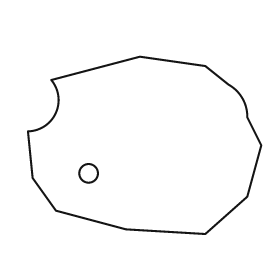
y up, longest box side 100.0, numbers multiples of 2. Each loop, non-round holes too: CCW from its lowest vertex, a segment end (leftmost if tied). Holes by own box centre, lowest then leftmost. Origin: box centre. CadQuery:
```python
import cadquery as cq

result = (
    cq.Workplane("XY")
    .moveTo(26.0, -38.0)
    .lineTo(44.0, -22.0)
    .lineTo(50.0, 0.0)
    .lineTo(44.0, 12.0)
    .threePointArc((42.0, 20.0), (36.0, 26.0))
    .lineTo(26.0, 34.0)
    .lineTo(-2.0, 38.0)
    .lineTo(-40.0, 28.0)
    .threePointArc((-38.0, 14.0), (-50.0, 6.0))
    .lineTo(-48.0, -14.0)
    .lineTo(-38.0, -28.0)
    .lineTo(-8.0, -36.0)
    .close()
    .moveTo(-24.0, -12.0)
    .circle(4.0)
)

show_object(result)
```